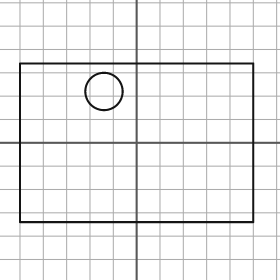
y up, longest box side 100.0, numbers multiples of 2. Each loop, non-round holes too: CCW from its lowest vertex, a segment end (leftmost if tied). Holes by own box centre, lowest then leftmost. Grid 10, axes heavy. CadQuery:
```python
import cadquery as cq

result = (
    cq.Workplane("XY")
    .moveTo(-50.0, -34.0)
    .lineTo(50.0, -34.0)
    .lineTo(50.0, 34.0)
    .lineTo(-50.0, 34.0)
    .close()
    .moveTo(-14.0, 22.0)
    .circle(8.0)
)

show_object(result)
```